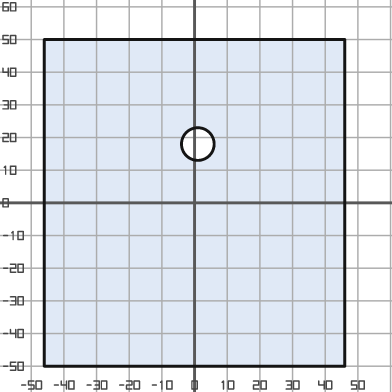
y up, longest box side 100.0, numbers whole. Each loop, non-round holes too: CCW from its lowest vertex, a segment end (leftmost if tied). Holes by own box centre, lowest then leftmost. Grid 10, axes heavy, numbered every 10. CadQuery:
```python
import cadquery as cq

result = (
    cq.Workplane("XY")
    .moveTo(-46.0, -50.0)
    .lineTo(46.0, -50.0)
    .lineTo(46.0, 50.0)
    .lineTo(-46.0, 50.0)
    .close()
    .moveTo(1.0, 18.0)
    .circle(5.0)
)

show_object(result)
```